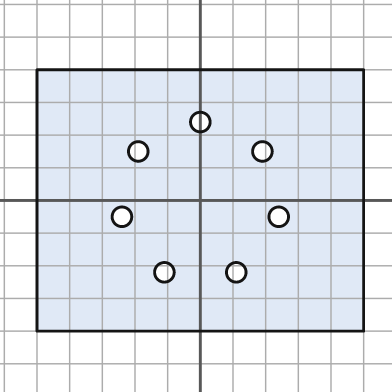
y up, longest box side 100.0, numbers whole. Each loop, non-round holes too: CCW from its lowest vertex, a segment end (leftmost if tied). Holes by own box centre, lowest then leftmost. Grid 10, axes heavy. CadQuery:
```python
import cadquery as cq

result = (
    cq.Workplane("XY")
    .moveTo(-50.0, -40.0)
    .lineTo(50.0, -40.0)
    .lineTo(50.0, 40.0)
    .lineTo(-50.0, 40.0)
    .close()
    .moveTo(-11.0, -22.0)
    .circle(3.0)
    .moveTo(11.0, -22.0)
    .circle(3.0)
    .moveTo(-24.0, -5.0)
    .circle(3.0)
    .moveTo(24.0, -5.0)
    .circle(3.0)
    .moveTo(-19.0, 15.0)
    .circle(3.0)
    .moveTo(19.0, 15.0)
    .circle(3.0)
    .moveTo(0.0, 24.0)
    .circle(3.0)
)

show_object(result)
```